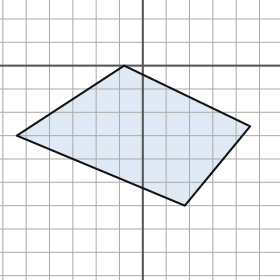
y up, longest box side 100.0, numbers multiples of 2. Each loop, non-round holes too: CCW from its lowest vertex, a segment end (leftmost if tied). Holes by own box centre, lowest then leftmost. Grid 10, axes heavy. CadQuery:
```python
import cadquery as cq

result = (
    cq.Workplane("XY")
    .moveTo(18.0, -60.0)
    .lineTo(46.0, -26.0)
    .lineTo(-8.0, 0.0)
    .lineTo(-54.0, -30.0)
    .close()
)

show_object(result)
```